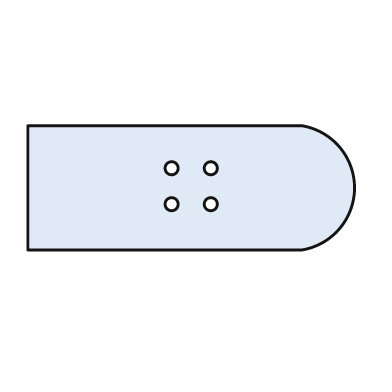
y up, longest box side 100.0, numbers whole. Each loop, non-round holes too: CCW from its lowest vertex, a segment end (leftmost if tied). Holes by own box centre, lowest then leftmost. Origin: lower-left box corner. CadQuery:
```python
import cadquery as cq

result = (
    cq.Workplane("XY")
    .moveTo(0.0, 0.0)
    .lineTo(84.0, 0.0)
    .threePointArc((100.0, 19.0), (84.0, 38.0))
    .lineTo(0.0, 38.0)
    .close()
    .moveTo(44.0, 14.0)
    .circle(2.0)
    .moveTo(56.0, 14.0)
    .circle(2.0)
    .moveTo(44.0, 25.0)
    .circle(2.0)
    .moveTo(56.0, 25.0)
    .circle(2.0)
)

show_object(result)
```